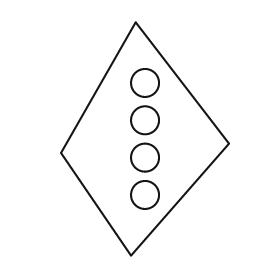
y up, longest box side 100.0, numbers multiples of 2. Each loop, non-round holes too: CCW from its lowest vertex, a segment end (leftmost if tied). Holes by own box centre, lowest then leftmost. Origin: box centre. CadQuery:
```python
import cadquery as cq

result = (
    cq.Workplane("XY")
    .moveTo(-6.0, -50.0)
    .lineTo(36.0, -2.0)
    .lineTo(-4.0, 50.0)
    .lineTo(-36.0, -6.0)
    .close()
    .moveTo(0.0, -24.0)
    .circle(6.0)
    .moveTo(0.0, -8.0)
    .circle(6.0)
    .moveTo(0.0, 8.0)
    .circle(6.0)
    .moveTo(0.0, 24.0)
    .circle(6.0)
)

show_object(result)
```